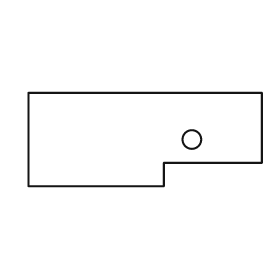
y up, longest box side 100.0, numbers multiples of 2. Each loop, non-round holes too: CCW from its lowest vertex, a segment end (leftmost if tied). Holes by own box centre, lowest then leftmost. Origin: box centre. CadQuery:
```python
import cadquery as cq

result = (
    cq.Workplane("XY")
    .moveTo(-50.0, -20.0)
    .lineTo(8.0, -20.0)
    .lineTo(8.0, -10.0)
    .lineTo(50.0, -10.0)
    .lineTo(50.0, 20.0)
    .lineTo(-50.0, 20.0)
    .close()
    .moveTo(20.0, 0.0)
    .circle(4.0)
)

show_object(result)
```